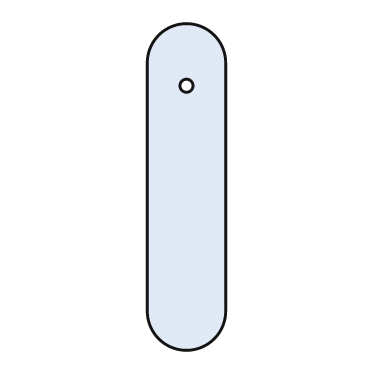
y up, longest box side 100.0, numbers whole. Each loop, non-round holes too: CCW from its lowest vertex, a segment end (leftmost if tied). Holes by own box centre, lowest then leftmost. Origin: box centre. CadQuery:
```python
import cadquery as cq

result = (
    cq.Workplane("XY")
    .moveTo(-12.0, -38.0)
    .threePointArc((0.0, -50.0), (12.0, -38.0))
    .lineTo(12.0, 38.0)
    .threePointArc((0.0, 50.0), (-12.0, 38.0))
    .close()
    .moveTo(0.0, 31.0)
    .circle(2.0)
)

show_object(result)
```